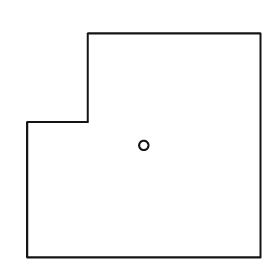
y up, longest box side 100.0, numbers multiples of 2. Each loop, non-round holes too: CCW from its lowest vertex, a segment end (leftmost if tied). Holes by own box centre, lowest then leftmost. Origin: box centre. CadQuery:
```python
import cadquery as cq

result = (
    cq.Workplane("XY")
    .moveTo(-50.0, -48.0)
    .lineTo(50.0, -48.0)
    .lineTo(50.0, 48.0)
    .lineTo(-24.0, 48.0)
    .lineTo(-24.0, 10.0)
    .lineTo(-50.0, 10.0)
    .close()
    .moveTo(0.0, 0.0)
    .circle(2.0)
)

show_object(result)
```